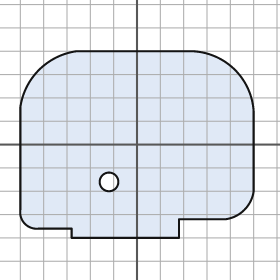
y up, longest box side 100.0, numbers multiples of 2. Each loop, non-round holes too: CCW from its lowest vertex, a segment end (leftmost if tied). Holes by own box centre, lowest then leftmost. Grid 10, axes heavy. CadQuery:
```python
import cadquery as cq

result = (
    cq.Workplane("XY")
    .moveTo(-28.0, -40.0)
    .lineTo(18.0, -40.0)
    .lineTo(18.0, -32.0)
    .lineTo(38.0, -32.0)
    .threePointArc((46.0, -28.0), (50.0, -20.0))
    .lineTo(50.0, 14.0)
    .threePointArc((42.0, 32.0), (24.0, 40.0))
    .lineTo(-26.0, 40.0)
    .threePointArc((-42.0, 32.0), (-50.0, 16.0))
    .lineTo(-50.0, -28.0)
    .threePointArc((-48.0, -34.0), (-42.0, -36.0))
    .lineTo(-28.0, -36.0)
    .close()
    .moveTo(-12.0, -16.0)
    .circle(4.0)
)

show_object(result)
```